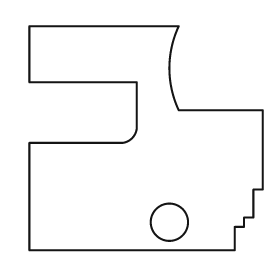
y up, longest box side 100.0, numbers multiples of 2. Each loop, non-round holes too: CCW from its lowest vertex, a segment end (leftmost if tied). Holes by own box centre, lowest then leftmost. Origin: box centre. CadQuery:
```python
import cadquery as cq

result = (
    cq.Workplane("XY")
    .moveTo(-50.0, -48.0)
    .lineTo(38.0, -48.0)
    .lineTo(38.0, -38.0)
    .lineTo(42.0, -38.0)
    .lineTo(42.0, -34.0)
    .lineTo(46.0, -34.0)
    .lineTo(46.0, -22.0)
    .lineTo(50.0, -22.0)
    .lineTo(50.0, 12.0)
    .lineTo(14.0, 12.0)
    .threePointArc((10.0, 30.0), (14.0, 48.0))
    .lineTo(-50.0, 48.0)
    .lineTo(-50.0, 24.0)
    .lineTo(-4.0, 24.0)
    .lineTo(-4.0, 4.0)
    .threePointArc((-6.0, 0.0), (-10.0, -2.0))
    .lineTo(-50.0, -2.0)
    .close()
    .moveTo(10.0, -36.0)
    .circle(8.0)
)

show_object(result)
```